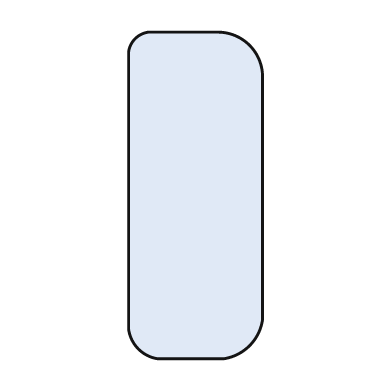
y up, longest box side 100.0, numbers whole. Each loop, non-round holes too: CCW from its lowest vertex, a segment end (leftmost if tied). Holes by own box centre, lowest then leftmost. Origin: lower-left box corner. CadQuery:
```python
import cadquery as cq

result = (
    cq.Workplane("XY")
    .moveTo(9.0, 0.0)
    .lineTo(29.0, 0.0)
    .threePointArc((37.0, 4.0), (41.0, 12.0))
    .lineTo(41.0, 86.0)
    .threePointArc((37.0, 96.0), (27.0, 100.0))
    .lineTo(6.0, 100.0)
    .threePointArc((2.0, 98.0), (0.0, 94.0))
    .lineTo(0.0, 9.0)
    .threePointArc((3.0, 3.0), (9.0, 0.0))
    .close()
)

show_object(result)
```